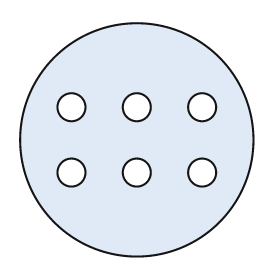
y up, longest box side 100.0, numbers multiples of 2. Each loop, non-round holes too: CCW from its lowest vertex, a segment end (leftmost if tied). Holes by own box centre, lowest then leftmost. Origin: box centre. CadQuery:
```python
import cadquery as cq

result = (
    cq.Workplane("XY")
    .moveTo(0.0, 0.0)
    .circle(50.0)
    .moveTo(-28.0, -14.0)
    .circle(6.0)
    .moveTo(0.0, -14.0)
    .circle(6.0)
    .moveTo(28.0, -14.0)
    .circle(6.0)
    .moveTo(-28.0, 14.0)
    .circle(6.0)
    .moveTo(0.0, 14.0)
    .circle(6.0)
    .moveTo(28.0, 14.0)
    .circle(6.0)
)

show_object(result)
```